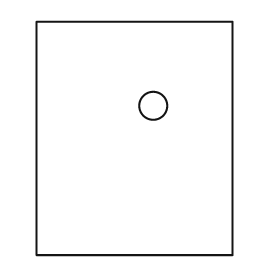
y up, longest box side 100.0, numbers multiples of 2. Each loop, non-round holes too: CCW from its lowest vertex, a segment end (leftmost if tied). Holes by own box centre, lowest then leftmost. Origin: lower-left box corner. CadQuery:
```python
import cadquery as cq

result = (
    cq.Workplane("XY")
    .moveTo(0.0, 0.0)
    .lineTo(84.0, 0.0)
    .lineTo(84.0, 100.0)
    .lineTo(0.0, 100.0)
    .close()
    .moveTo(50.0, 64.0)
    .circle(6.0)
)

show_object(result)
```